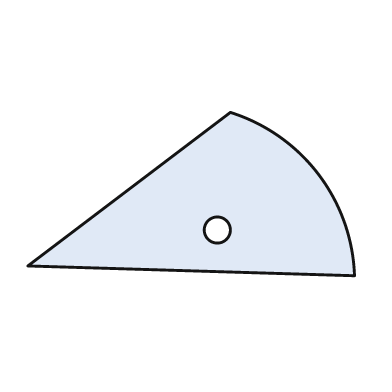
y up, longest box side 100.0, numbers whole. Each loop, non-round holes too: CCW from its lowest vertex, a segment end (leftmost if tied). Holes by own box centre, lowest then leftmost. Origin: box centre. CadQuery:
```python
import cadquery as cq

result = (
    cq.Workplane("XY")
    .moveTo(50.0, -25.0)
    .threePointArc((39.0, 6.0), (12.0, 25.0))
    .lineTo(-50.0, -22.0)
    .close()
    .moveTo(8.0, -11.0)
    .circle(4.0)
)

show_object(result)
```